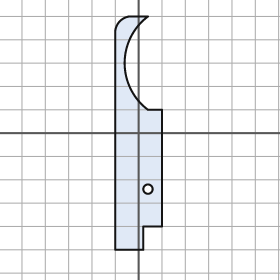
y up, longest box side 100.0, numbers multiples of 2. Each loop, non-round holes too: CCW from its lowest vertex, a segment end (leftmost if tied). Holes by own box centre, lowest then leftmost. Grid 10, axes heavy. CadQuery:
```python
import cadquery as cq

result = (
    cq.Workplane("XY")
    .moveTo(-10.0, -50.0)
    .lineTo(2.0, -50.0)
    .lineTo(2.0, -40.0)
    .lineTo(10.0, -40.0)
    .lineTo(10.0, 10.0)
    .lineTo(4.0, 10.0)
    .threePointArc((-6.0, 30.0), (4.0, 50.0))
    .lineTo(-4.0, 50.0)
    .threePointArc((-8.0, 48.0), (-10.0, 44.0))
    .close()
    .moveTo(4.0, -24.0)
    .circle(2.0)
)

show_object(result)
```